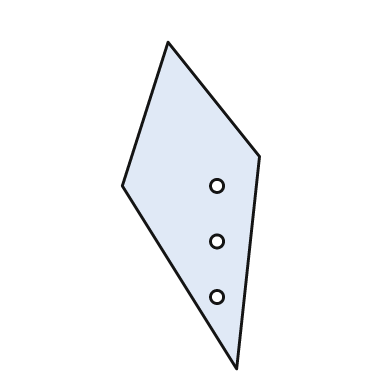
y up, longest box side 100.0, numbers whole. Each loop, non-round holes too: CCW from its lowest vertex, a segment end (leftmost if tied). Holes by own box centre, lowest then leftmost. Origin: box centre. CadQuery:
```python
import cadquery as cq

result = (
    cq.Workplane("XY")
    .moveTo(14.0, -50.0)
    .lineTo(21.0, 15.0)
    .lineTo(-7.0, 50.0)
    .lineTo(-21.0, 6.0)
    .close()
    .moveTo(8.0, -28.0)
    .circle(2.0)
    .moveTo(8.0, -11.0)
    .circle(2.0)
    .moveTo(8.0, 6.0)
    .circle(2.0)
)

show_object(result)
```